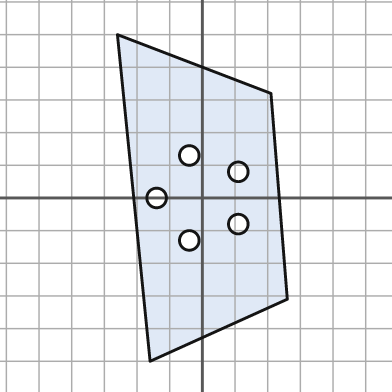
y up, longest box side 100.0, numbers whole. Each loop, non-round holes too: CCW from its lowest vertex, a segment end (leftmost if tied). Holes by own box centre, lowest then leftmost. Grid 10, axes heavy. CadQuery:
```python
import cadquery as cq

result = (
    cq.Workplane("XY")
    .moveTo(-16.0, -50.0)
    .lineTo(26.0, -31.0)
    .lineTo(21.0, 32.0)
    .lineTo(-26.0, 50.0)
    .close()
    .moveTo(-4.0, -13.0)
    .circle(3.0)
    .moveTo(11.0, -8.0)
    .circle(3.0)
    .moveTo(-14.0, 0.0)
    .circle(3.0)
    .moveTo(11.0, 8.0)
    .circle(3.0)
    .moveTo(-4.0, 13.0)
    .circle(3.0)
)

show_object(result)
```